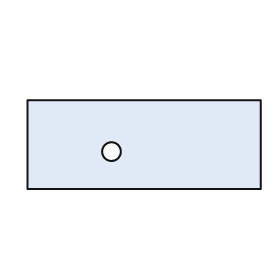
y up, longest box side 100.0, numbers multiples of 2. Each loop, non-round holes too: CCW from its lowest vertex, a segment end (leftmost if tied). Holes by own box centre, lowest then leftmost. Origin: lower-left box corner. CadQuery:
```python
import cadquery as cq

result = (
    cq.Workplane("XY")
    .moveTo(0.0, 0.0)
    .lineTo(100.0, 0.0)
    .lineTo(100.0, 38.0)
    .lineTo(0.0, 38.0)
    .close()
    .moveTo(36.0, 16.0)
    .circle(4.0)
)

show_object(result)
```